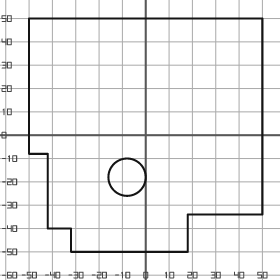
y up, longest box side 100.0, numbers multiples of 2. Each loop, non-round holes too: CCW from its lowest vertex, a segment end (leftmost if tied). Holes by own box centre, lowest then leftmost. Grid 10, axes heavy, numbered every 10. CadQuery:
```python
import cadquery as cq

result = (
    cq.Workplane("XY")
    .moveTo(-32.0, -50.0)
    .lineTo(18.0, -50.0)
    .lineTo(18.0, -34.0)
    .lineTo(50.0, -34.0)
    .lineTo(50.0, 50.0)
    .lineTo(-50.0, 50.0)
    .lineTo(-50.0, -8.0)
    .lineTo(-42.0, -8.0)
    .lineTo(-42.0, -40.0)
    .lineTo(-32.0, -40.0)
    .close()
    .moveTo(-8.0, -18.0)
    .circle(8.0)
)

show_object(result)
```